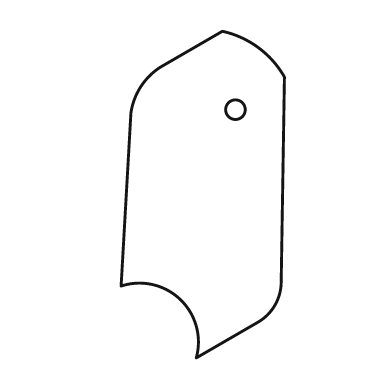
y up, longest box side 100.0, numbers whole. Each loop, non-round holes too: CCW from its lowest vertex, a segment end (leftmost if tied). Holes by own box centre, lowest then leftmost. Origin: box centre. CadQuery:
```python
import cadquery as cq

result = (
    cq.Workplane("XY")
    .moveTo(-2.0, -50.0)
    .lineTo(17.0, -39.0)
    .threePointArc((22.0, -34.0), (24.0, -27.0))
    .lineTo(25.0, 36.0)
    .threePointArc((17.0, 45.0), (6.0, 50.0))
    .lineTo(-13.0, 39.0)
    .threePointArc((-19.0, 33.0), (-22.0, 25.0))
    .lineTo(-25.0, -28.0)
    .threePointArc((-7.0, -32.0), (-2.0, -50.0))
    .close()
    .moveTo(10.0, 26.0)
    .circle(3.0)
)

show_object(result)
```